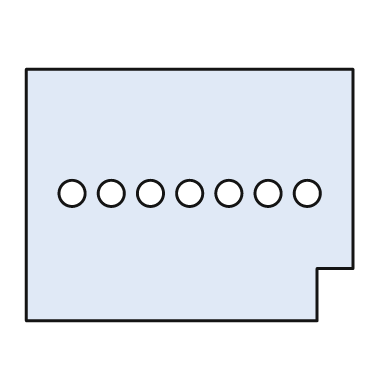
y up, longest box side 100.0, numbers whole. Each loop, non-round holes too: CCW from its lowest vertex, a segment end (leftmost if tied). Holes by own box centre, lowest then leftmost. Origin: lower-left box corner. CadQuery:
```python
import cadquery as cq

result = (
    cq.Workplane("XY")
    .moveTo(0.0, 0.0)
    .lineTo(89.0, 0.0)
    .lineTo(89.0, 16.0)
    .lineTo(100.0, 16.0)
    .lineTo(100.0, 77.0)
    .lineTo(0.0, 77.0)
    .close()
    .moveTo(14.0, 39.0)
    .circle(4.0)
    .moveTo(26.0, 39.0)
    .circle(4.0)
    .moveTo(38.0, 39.0)
    .circle(4.0)
    .moveTo(50.0, 39.0)
    .circle(4.0)
    .moveTo(62.0, 39.0)
    .circle(4.0)
    .moveTo(74.0, 39.0)
    .circle(4.0)
    .moveTo(86.0, 39.0)
    .circle(4.0)
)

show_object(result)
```